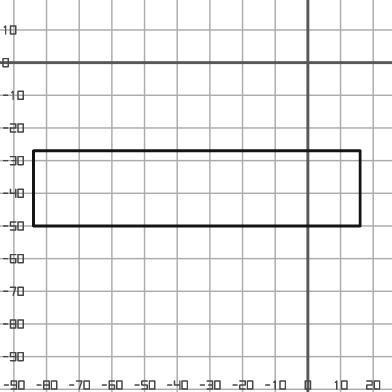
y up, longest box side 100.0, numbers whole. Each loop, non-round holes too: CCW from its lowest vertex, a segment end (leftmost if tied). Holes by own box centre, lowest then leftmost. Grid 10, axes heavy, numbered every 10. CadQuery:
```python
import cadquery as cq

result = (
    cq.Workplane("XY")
    .moveTo(-84.0, -50.0)
    .lineTo(16.0, -50.0)
    .lineTo(16.0, -27.0)
    .lineTo(-84.0, -27.0)
    .close()
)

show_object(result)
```